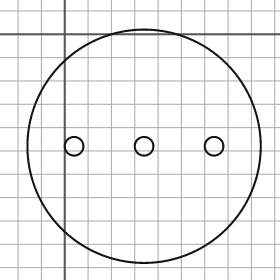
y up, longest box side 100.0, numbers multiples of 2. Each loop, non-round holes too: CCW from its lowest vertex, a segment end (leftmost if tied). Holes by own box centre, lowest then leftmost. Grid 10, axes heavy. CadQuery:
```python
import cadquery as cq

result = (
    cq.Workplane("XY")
    .moveTo(34.0, -48.0)
    .circle(50.0)
    .moveTo(4.0, -48.0)
    .circle(4.0)
    .moveTo(34.0, -48.0)
    .circle(4.0)
    .moveTo(64.0, -48.0)
    .circle(4.0)
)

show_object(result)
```